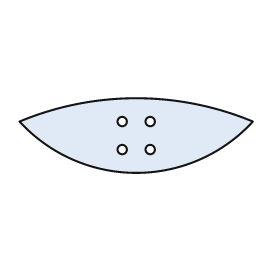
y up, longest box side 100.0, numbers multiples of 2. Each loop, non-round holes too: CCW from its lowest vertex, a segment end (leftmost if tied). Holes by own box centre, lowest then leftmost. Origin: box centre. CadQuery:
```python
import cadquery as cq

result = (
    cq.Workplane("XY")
    .moveTo(-50.0, 6.0)
    .threePointArc((0.0, -16.0), (50.0, 6.0))
    .threePointArc((0.0, 16.0), (-50.0, 6.0))
    .close()
    .moveTo(-6.0, -6.0)
    .circle(2.0)
    .moveTo(6.0, -6.0)
    .circle(2.0)
    .moveTo(-6.0, 6.0)
    .circle(2.0)
    .moveTo(6.0, 6.0)
    .circle(2.0)
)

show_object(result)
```